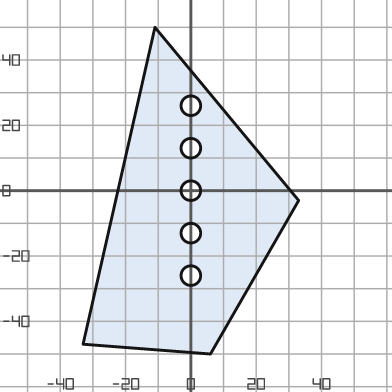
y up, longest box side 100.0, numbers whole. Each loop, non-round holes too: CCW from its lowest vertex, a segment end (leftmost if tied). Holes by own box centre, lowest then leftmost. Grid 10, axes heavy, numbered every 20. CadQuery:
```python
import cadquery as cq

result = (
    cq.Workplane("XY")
    .moveTo(6.0, -50.0)
    .lineTo(33.0, -3.0)
    .lineTo(-11.0, 50.0)
    .lineTo(-33.0, -47.0)
    .close()
    .moveTo(0.0, -26.0)
    .circle(3.0)
    .moveTo(0.0, -13.0)
    .circle(3.0)
    .moveTo(0.0, 0.0)
    .circle(3.0)
    .moveTo(0.0, 13.0)
    .circle(3.0)
    .moveTo(0.0, 26.0)
    .circle(3.0)
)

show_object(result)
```